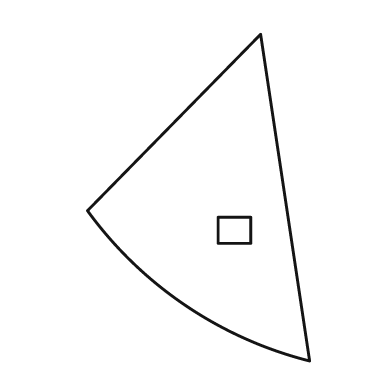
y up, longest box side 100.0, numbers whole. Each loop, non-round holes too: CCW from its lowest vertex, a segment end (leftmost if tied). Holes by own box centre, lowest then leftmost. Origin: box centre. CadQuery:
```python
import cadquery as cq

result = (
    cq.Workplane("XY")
    .moveTo(34.0, -50.0)
    .lineTo(19.0, 50.0)
    .lineTo(-34.0, -4.0)
    .threePointArc((-4.0, -33.0), (34.0, -50.0))
    .close()
    .moveTo(6.0, -14.0)
    .lineTo(16.0, -14.0)
    .lineTo(16.0, -6.0)
    .lineTo(6.0, -6.0)
    .close()
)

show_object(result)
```